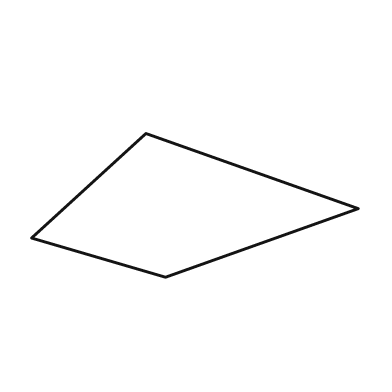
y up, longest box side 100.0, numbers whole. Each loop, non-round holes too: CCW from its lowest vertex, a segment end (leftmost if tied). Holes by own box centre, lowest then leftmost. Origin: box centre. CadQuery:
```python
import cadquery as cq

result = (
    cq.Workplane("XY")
    .moveTo(-9.0, -22.0)
    .lineTo(50.0, -1.0)
    .lineTo(-15.0, 22.0)
    .lineTo(-50.0, -10.0)
    .close()
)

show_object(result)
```